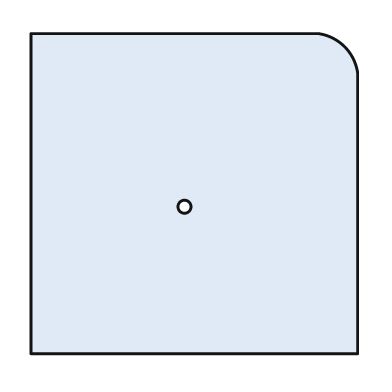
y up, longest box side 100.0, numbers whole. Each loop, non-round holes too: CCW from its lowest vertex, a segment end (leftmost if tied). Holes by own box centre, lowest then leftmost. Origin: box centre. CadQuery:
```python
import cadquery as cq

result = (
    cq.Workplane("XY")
    .moveTo(-50.0, -49.0)
    .lineTo(50.0, -49.0)
    .lineTo(50.0, 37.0)
    .threePointArc((46.0, 45.0), (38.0, 49.0))
    .lineTo(-50.0, 49.0)
    .close()
    .moveTo(-3.0, -4.0)
    .circle(2.0)
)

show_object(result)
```